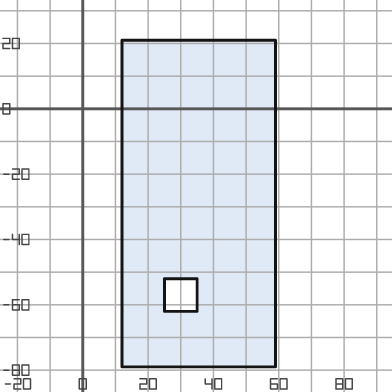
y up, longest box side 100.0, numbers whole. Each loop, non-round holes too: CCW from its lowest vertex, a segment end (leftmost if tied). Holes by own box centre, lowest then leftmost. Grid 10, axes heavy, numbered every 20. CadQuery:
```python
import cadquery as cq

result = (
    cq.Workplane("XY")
    .moveTo(12.0, -79.0)
    .lineTo(59.0, -79.0)
    .lineTo(59.0, 21.0)
    .lineTo(12.0, 21.0)
    .close()
    .moveTo(25.0, -62.0)
    .lineTo(35.0, -62.0)
    .lineTo(35.0, -52.0)
    .lineTo(25.0, -52.0)
    .close()
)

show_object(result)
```